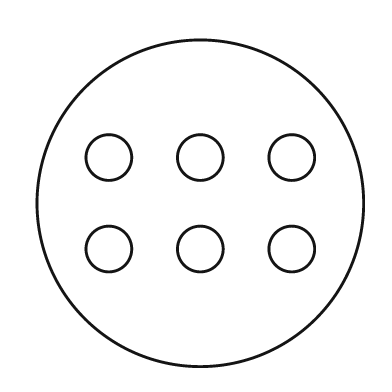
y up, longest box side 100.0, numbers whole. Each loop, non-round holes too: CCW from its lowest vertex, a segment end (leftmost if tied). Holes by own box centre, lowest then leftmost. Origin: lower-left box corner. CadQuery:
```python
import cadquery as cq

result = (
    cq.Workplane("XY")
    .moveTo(50.0, 50.0)
    .circle(50.0)
    .moveTo(22.0, 36.0)
    .circle(7.0)
    .moveTo(50.0, 36.0)
    .circle(7.0)
    .moveTo(78.0, 36.0)
    .circle(7.0)
    .moveTo(22.0, 64.0)
    .circle(7.0)
    .moveTo(50.0, 64.0)
    .circle(7.0)
    .moveTo(78.0, 64.0)
    .circle(7.0)
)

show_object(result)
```